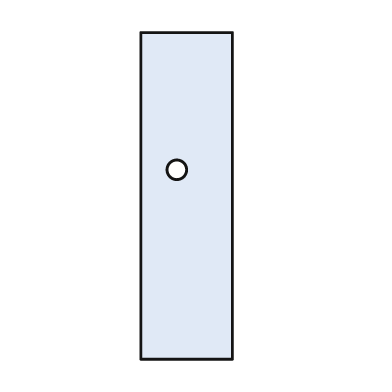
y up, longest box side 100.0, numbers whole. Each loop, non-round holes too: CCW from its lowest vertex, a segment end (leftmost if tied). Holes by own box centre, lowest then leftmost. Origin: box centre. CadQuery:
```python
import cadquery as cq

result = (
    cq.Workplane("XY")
    .moveTo(-14.0, -50.0)
    .lineTo(14.0, -50.0)
    .lineTo(14.0, 50.0)
    .lineTo(-14.0, 50.0)
    .close()
    .moveTo(-3.0, 8.0)
    .circle(3.0)
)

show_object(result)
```